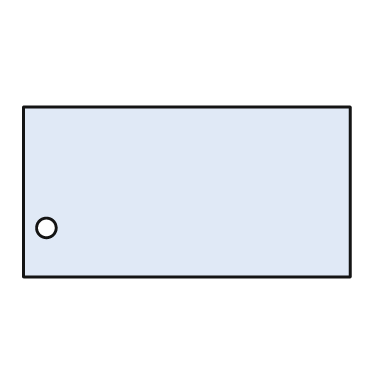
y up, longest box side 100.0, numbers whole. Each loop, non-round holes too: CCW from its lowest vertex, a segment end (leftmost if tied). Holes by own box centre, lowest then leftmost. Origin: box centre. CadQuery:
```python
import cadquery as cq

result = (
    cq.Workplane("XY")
    .moveTo(-50.0, -26.0)
    .lineTo(50.0, -26.0)
    .lineTo(50.0, 26.0)
    .lineTo(-50.0, 26.0)
    .close()
    .moveTo(-43.0, -11.0)
    .circle(3.0)
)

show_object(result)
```